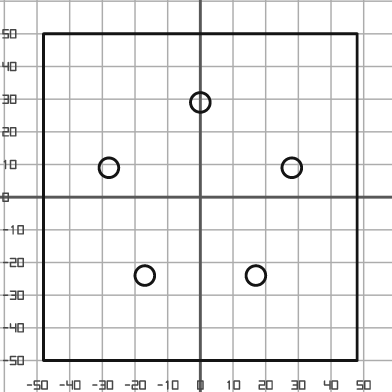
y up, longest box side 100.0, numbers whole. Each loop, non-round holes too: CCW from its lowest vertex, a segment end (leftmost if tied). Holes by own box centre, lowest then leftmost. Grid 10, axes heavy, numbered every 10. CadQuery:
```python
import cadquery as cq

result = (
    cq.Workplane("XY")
    .moveTo(-48.0, -50.0)
    .lineTo(48.0, -50.0)
    .lineTo(48.0, 50.0)
    .lineTo(-48.0, 50.0)
    .close()
    .moveTo(-17.0, -24.0)
    .circle(3.0)
    .moveTo(17.0, -24.0)
    .circle(3.0)
    .moveTo(-28.0, 9.0)
    .circle(3.0)
    .moveTo(28.0, 9.0)
    .circle(3.0)
    .moveTo(0.0, 29.0)
    .circle(3.0)
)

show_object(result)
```